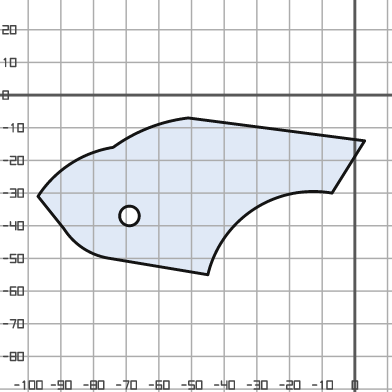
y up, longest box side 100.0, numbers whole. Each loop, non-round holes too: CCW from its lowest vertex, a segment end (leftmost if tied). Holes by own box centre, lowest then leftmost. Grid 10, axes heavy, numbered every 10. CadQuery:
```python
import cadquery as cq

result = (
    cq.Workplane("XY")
    .moveTo(-45.0, -55.0)
    .threePointArc((-31.0, -35.0), (-7.0, -30.0))
    .lineTo(3.0, -14.0)
    .lineTo(-51.0, -7.0)
    .threePointArc((-63.0, -10.0), (-74.0, -16.0))
    .threePointArc((-87.0, -21.0), (-97.0, -31.0))
    .lineTo(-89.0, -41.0)
    .threePointArc((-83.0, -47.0), (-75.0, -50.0))
    .close()
    .moveTo(-69.0, -37.0)
    .circle(3.0)
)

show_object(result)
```